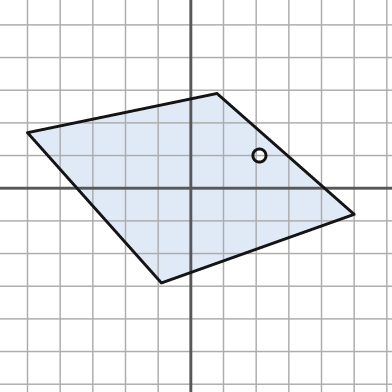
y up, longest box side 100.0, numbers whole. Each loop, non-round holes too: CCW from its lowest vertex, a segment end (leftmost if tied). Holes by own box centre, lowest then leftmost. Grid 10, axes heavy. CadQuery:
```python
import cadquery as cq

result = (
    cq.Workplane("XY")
    .moveTo(-9.0, -29.0)
    .lineTo(50.0, -8.0)
    .lineTo(8.0, 29.0)
    .lineTo(-50.0, 17.0)
    .close()
    .moveTo(21.0, 10.0)
    .circle(2.0)
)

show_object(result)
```